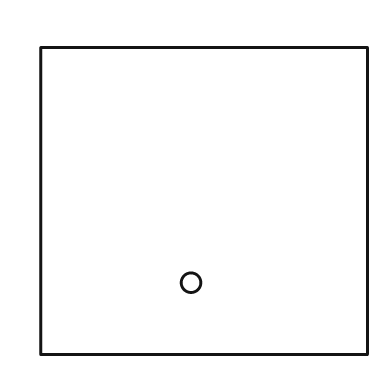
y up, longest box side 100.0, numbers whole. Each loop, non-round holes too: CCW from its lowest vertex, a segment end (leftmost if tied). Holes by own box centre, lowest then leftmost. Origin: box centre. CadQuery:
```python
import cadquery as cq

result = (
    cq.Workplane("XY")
    .moveTo(-50.0, -47.0)
    .lineTo(50.0, -47.0)
    .lineTo(50.0, 47.0)
    .lineTo(-50.0, 47.0)
    .close()
    .moveTo(-4.0, -25.0)
    .circle(3.0)
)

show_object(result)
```